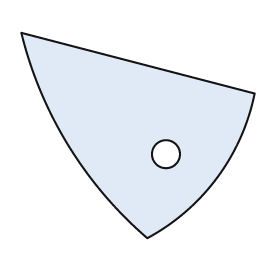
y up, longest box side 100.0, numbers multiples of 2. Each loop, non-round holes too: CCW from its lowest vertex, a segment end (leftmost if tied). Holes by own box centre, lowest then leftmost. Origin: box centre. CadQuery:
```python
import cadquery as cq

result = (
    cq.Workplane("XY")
    .moveTo(4.0, -44.0)
    .threePointArc((34.0, -18.0), (50.0, 18.0))
    .lineTo(-50.0, 44.0)
    .threePointArc((-30.0, -4.0), (4.0, -44.0))
    .close()
    .moveTo(12.0, -8.0)
    .circle(6.0)
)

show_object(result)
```